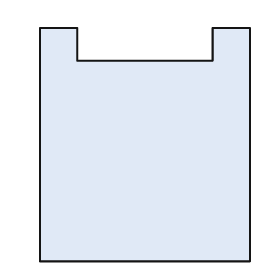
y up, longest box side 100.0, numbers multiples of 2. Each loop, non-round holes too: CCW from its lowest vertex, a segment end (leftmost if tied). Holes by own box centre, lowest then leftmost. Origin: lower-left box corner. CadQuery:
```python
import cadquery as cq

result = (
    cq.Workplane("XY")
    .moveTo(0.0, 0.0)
    .lineTo(90.0, 0.0)
    .lineTo(90.0, 100.0)
    .lineTo(74.0, 100.0)
    .lineTo(74.0, 86.0)
    .lineTo(16.0, 86.0)
    .lineTo(16.0, 100.0)
    .lineTo(0.0, 100.0)
    .close()
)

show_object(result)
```